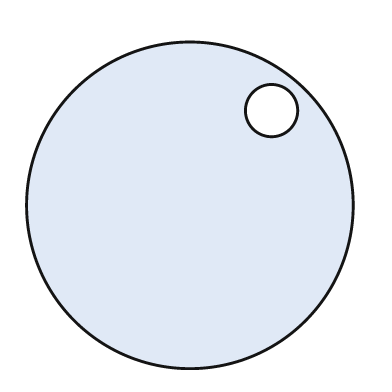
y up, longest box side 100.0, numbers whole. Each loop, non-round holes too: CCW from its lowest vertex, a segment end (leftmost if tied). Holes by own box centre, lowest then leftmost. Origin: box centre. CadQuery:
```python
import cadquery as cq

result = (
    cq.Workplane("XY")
    .moveTo(0.0, 0.0)
    .circle(50.0)
    .moveTo(25.0, 29.0)
    .circle(8.0)
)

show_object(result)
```